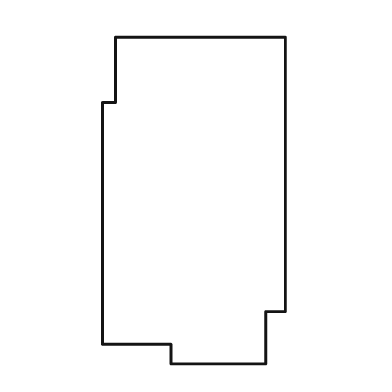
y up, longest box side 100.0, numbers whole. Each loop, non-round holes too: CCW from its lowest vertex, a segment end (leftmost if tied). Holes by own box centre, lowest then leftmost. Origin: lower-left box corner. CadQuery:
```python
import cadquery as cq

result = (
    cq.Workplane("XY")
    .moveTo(21.0, 0.0)
    .lineTo(50.0, 0.0)
    .lineTo(50.0, 16.0)
    .lineTo(56.0, 16.0)
    .lineTo(56.0, 100.0)
    .lineTo(4.0, 100.0)
    .lineTo(4.0, 80.0)
    .lineTo(0.0, 80.0)
    .lineTo(0.0, 6.0)
    .lineTo(21.0, 6.0)
    .close()
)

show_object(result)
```